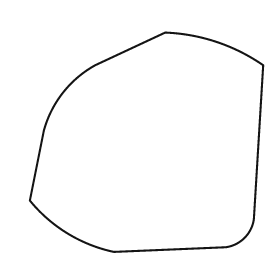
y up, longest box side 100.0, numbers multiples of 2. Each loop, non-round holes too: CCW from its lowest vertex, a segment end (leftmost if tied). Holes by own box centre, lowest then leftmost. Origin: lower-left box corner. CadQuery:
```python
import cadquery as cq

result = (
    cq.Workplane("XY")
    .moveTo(36.0, 0.0)
    .lineTo(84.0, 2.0)
    .threePointArc((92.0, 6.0), (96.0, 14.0))
    .lineTo(100.0, 80.0)
    .threePointArc((80.0, 90.0), (58.0, 94.0))
    .lineTo(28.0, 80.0)
    .threePointArc((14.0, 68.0), (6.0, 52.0))
    .lineTo(0.0, 22.0)
    .threePointArc((16.0, 8.0), (36.0, 0.0))
    .close()
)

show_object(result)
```